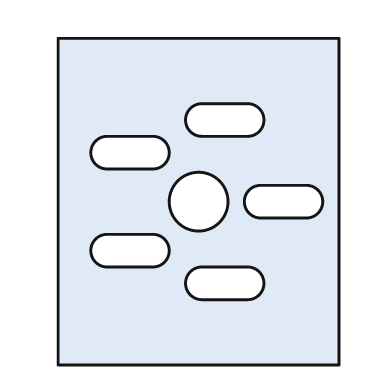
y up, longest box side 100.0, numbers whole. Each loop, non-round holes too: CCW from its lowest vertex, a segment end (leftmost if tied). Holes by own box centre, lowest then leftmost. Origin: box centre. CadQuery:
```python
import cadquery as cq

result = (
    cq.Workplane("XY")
    .moveTo(-43.0, -50.0)
    .lineTo(43.0, -50.0)
    .lineTo(43.0, 50.0)
    .lineTo(-43.0, 50.0)
    .close()
    .moveTo(1.0, -30.0)
    .lineTo(15.0, -30.0)
    .threePointArc((20.0, -25.0), (15.0, -20.0))
    .lineTo(1.0, -20.0)
    .threePointArc((-4.0, -25.0), (1.0, -30.0))
    .close()
    .moveTo(-28.0, -20.0)
    .lineTo(-14.0, -20.0)
    .threePointArc((-9.0, -15.0), (-14.0, -10.0))
    .lineTo(-28.0, -10.0)
    .threePointArc((-33.0, -15.0), (-28.0, -20.0))
    .close()
    .moveTo(0.0, 0.0)
    .circle(9.0)
    .moveTo(19.0, -5.0)
    .lineTo(33.0, -5.0)
    .threePointArc((38.0, 0.0), (33.0, 5.0))
    .lineTo(19.0, 5.0)
    .threePointArc((14.0, 0.0), (19.0, -5.0))
    .close()
    .moveTo(-28.0, 10.0)
    .lineTo(-14.0, 10.0)
    .threePointArc((-9.0, 15.0), (-14.0, 20.0))
    .lineTo(-28.0, 20.0)
    .threePointArc((-33.0, 15.0), (-28.0, 10.0))
    .close()
    .moveTo(1.0, 20.0)
    .lineTo(15.0, 20.0)
    .threePointArc((20.0, 25.0), (15.0, 30.0))
    .lineTo(1.0, 30.0)
    .threePointArc((-4.0, 25.0), (1.0, 20.0))
    .close()
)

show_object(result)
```